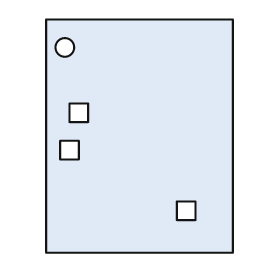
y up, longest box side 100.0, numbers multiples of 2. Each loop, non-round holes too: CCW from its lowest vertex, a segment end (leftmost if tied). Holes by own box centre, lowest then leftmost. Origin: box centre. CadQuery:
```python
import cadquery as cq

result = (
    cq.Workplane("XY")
    .moveTo(-40.0, -50.0)
    .lineTo(40.0, -50.0)
    .lineTo(40.0, 50.0)
    .lineTo(-40.0, 50.0)
    .close()
    .moveTo(16.0, -36.0)
    .lineTo(24.0, -36.0)
    .lineTo(24.0, -28.0)
    .lineTo(16.0, -28.0)
    .close()
    .moveTo(-34.0, -10.0)
    .lineTo(-26.0, -10.0)
    .lineTo(-26.0, -2.0)
    .lineTo(-34.0, -2.0)
    .close()
    .moveTo(-30.0, 6.0)
    .lineTo(-22.0, 6.0)
    .lineTo(-22.0, 14.0)
    .lineTo(-30.0, 14.0)
    .close()
    .moveTo(-32.0, 38.0)
    .circle(4.0)
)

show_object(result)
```